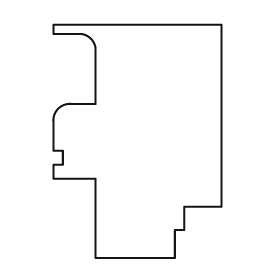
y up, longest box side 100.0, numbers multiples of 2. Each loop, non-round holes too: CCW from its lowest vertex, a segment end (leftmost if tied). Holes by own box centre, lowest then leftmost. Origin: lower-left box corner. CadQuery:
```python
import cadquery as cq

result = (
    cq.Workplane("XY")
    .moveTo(18.0, 0.0)
    .lineTo(52.0, 0.0)
    .lineTo(52.0, 12.0)
    .lineTo(56.0, 12.0)
    .lineTo(56.0, 22.0)
    .lineTo(72.0, 22.0)
    .lineTo(72.0, 100.0)
    .lineTo(0.0, 100.0)
    .lineTo(0.0, 96.0)
    .lineTo(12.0, 96.0)
    .threePointArc((16.0, 94.0), (18.0, 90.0))
    .lineTo(18.0, 66.0)
    .lineTo(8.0, 66.0)
    .threePointArc((2.0, 64.0), (0.0, 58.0))
    .lineTo(0.0, 46.0)
    .lineTo(4.0, 46.0)
    .lineTo(4.0, 40.0)
    .lineTo(0.0, 40.0)
    .lineTo(0.0, 34.0)
    .lineTo(18.0, 34.0)
    .close()
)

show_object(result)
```